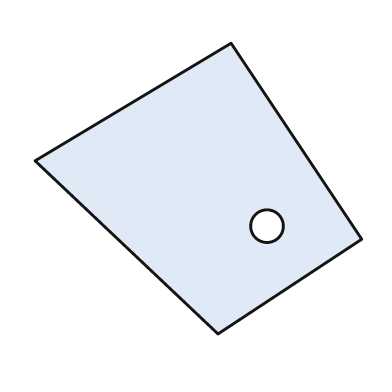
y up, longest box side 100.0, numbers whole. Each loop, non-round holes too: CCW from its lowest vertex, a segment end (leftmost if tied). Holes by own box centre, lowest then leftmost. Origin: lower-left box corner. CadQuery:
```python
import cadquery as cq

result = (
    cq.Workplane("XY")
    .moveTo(56.0, 0.0)
    .lineTo(100.0, 29.0)
    .lineTo(60.0, 89.0)
    .lineTo(0.0, 53.0)
    .close()
    .moveTo(71.0, 33.0)
    .circle(5.0)
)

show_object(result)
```